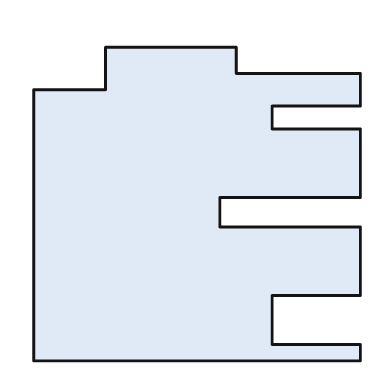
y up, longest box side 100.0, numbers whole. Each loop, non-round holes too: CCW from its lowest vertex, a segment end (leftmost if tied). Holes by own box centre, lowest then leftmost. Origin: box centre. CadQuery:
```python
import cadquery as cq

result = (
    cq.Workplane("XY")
    .moveTo(-50.0, -48.0)
    .lineTo(50.0, -48.0)
    .lineTo(50.0, -43.0)
    .lineTo(23.0, -43.0)
    .lineTo(23.0, -28.0)
    .lineTo(50.0, -28.0)
    .lineTo(50.0, -7.0)
    .lineTo(7.0, -7.0)
    .lineTo(7.0, 2.0)
    .lineTo(50.0, 2.0)
    .lineTo(50.0, 23.0)
    .lineTo(23.0, 23.0)
    .lineTo(23.0, 30.0)
    .lineTo(50.0, 30.0)
    .lineTo(50.0, 40.0)
    .lineTo(12.0, 40.0)
    .lineTo(12.0, 48.0)
    .lineTo(-28.0, 48.0)
    .lineTo(-28.0, 35.0)
    .lineTo(-50.0, 35.0)
    .close()
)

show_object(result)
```